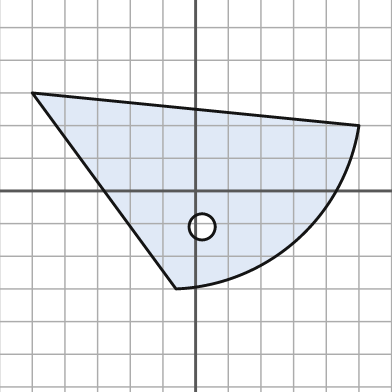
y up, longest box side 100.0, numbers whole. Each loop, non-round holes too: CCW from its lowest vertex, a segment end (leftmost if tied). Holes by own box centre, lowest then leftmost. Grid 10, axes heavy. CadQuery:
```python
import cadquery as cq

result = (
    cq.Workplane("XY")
    .moveTo(-6.0, -30.0)
    .threePointArc((31.0, -15.0), (50.0, 20.0))
    .lineTo(-50.0, 30.0)
    .close()
    .moveTo(2.0, -11.0)
    .circle(4.0)
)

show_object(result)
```